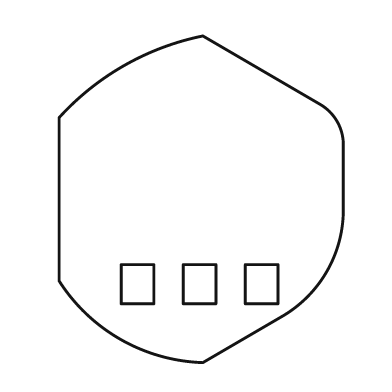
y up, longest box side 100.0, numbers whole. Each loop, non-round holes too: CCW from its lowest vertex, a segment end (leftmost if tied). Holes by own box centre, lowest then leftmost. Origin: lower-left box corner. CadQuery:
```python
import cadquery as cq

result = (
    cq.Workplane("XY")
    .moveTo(44.0, 0.0)
    .lineTo(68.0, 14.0)
    .threePointArc((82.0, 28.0), (87.0, 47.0))
    .lineTo(87.0, 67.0)
    .threePointArc((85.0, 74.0), (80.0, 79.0))
    .lineTo(44.0, 100.0)
    .threePointArc((20.0, 91.0), (0.0, 75.0))
    .lineTo(0.0, 25.0)
    .threePointArc((19.0, 7.0), (44.0, 0.0))
    .close()
    .moveTo(19.0, 18.0)
    .lineTo(29.0, 18.0)
    .lineTo(29.0, 30.0)
    .lineTo(19.0, 30.0)
    .close()
    .moveTo(38.0, 18.0)
    .lineTo(48.0, 18.0)
    .lineTo(48.0, 30.0)
    .lineTo(38.0, 30.0)
    .close()
    .moveTo(57.0, 18.0)
    .lineTo(67.0, 18.0)
    .lineTo(67.0, 30.0)
    .lineTo(57.0, 30.0)
    .close()
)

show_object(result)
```